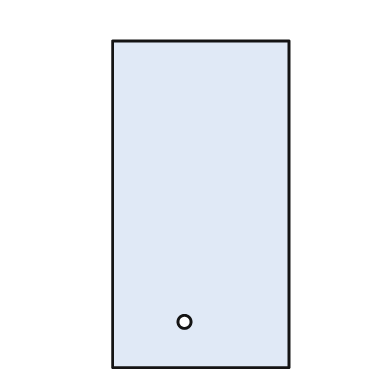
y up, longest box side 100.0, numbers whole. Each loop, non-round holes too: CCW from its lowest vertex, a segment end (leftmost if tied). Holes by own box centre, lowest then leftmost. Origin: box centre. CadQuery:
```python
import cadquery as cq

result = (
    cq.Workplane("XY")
    .moveTo(-27.0, -50.0)
    .lineTo(27.0, -50.0)
    .lineTo(27.0, 50.0)
    .lineTo(-27.0, 50.0)
    .close()
    .moveTo(-5.0, -36.0)
    .circle(2.0)
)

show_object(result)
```